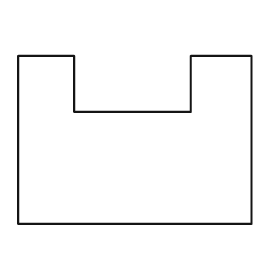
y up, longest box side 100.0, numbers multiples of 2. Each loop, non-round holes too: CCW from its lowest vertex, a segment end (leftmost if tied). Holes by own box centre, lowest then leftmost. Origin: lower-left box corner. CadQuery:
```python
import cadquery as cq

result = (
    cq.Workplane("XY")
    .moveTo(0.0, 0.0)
    .lineTo(100.0, 0.0)
    .lineTo(100.0, 72.0)
    .lineTo(74.0, 72.0)
    .lineTo(74.0, 48.0)
    .lineTo(24.0, 48.0)
    .lineTo(24.0, 72.0)
    .lineTo(0.0, 72.0)
    .close()
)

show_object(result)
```